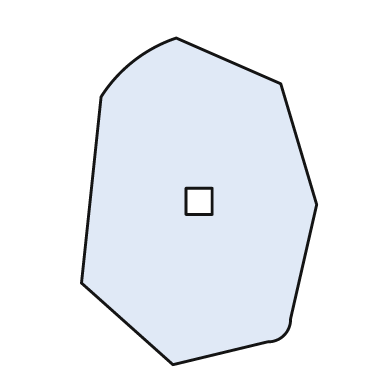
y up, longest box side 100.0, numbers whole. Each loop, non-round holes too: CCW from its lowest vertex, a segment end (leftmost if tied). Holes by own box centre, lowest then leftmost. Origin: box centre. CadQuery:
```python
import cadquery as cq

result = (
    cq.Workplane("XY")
    .moveTo(-8.0, -50.0)
    .lineTo(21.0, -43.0)
    .threePointArc((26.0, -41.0), (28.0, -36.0))
    .lineTo(36.0, -1.0)
    .lineTo(25.0, 36.0)
    .lineTo(-7.0, 50.0)
    .threePointArc((-20.0, 43.0), (-30.0, 32.0))
    .lineTo(-36.0, -25.0)
    .close()
    .moveTo(-4.0, -4.0)
    .lineTo(4.0, -4.0)
    .lineTo(4.0, 4.0)
    .lineTo(-4.0, 4.0)
    .close()
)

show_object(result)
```